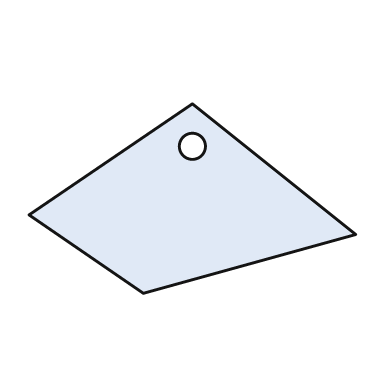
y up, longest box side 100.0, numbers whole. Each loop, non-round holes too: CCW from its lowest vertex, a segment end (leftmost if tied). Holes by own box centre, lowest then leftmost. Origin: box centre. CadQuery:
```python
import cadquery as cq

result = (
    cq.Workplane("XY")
    .moveTo(-15.0, -29.0)
    .lineTo(50.0, -11.0)
    .lineTo(0.0, 29.0)
    .lineTo(-50.0, -5.0)
    .close()
    .moveTo(0.0, 16.0)
    .circle(4.0)
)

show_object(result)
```